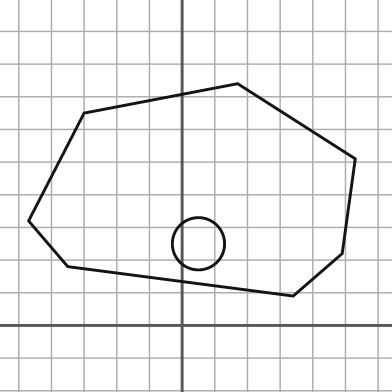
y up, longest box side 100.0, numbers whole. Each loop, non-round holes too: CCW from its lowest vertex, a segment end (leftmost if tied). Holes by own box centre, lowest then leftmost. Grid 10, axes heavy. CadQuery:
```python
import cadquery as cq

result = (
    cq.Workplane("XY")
    .moveTo(34.0, 9.0)
    .lineTo(49.0, 22.0)
    .lineTo(53.0, 51.0)
    .lineTo(17.0, 74.0)
    .lineTo(-30.0, 65.0)
    .lineTo(-47.0, 32.0)
    .lineTo(-35.0, 18.0)
    .close()
    .moveTo(5.0, 25.0)
    .circle(8.0)
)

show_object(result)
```